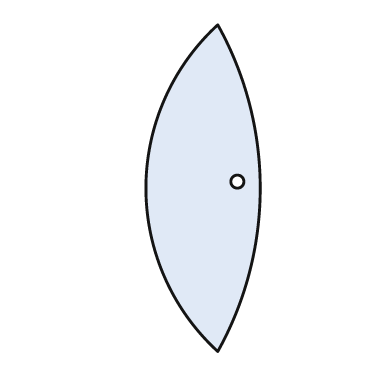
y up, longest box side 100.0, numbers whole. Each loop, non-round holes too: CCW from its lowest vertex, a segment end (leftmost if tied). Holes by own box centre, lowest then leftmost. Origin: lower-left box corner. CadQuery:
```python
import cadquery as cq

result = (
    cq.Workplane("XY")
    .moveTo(22.0, 0.0)
    .threePointArc((35.0, 50.0), (22.0, 100.0))
    .threePointArc((0.0, 50.0), (22.0, 0.0))
    .close()
    .moveTo(28.0, 52.0)
    .circle(2.0)
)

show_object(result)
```